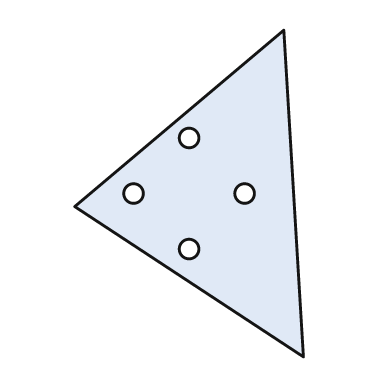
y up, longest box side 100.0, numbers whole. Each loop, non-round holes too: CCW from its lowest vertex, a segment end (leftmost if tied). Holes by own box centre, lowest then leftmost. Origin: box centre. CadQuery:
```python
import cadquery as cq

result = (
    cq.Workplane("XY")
    .moveTo(35.0, -50.0)
    .lineTo(29.0, 50.0)
    .lineTo(-35.0, -4.0)
    .close()
    .moveTo(0.0, -17.0)
    .circle(3.0)
    .moveTo(-17.0, 0.0)
    .circle(3.0)
    .moveTo(17.0, 0.0)
    .circle(3.0)
    .moveTo(0.0, 17.0)
    .circle(3.0)
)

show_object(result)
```